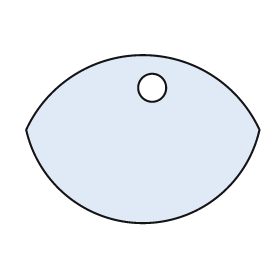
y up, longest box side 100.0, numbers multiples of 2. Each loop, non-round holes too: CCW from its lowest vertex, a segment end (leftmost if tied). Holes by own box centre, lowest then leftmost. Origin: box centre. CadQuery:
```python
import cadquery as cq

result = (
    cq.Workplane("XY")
    .moveTo(-50.0, 4.0)
    .threePointArc((0.0, -36.0), (50.0, 4.0))
    .threePointArc((0.0, 36.0), (-50.0, 4.0))
    .close()
    .moveTo(4.0, 22.0)
    .circle(6.0)
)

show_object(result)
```